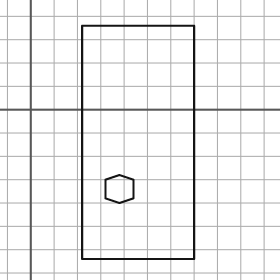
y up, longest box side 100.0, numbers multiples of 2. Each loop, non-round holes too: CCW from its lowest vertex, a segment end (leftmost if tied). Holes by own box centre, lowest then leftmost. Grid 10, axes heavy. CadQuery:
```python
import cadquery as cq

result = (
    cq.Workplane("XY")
    .moveTo(22.0, -64.0)
    .lineTo(70.0, -64.0)
    .lineTo(70.0, 36.0)
    .lineTo(22.0, 36.0)
    .close()
    .moveTo(38.0, -40.0)
    .lineTo(44.0, -38.0)
    .lineTo(44.0, -30.0)
    .lineTo(38.0, -28.0)
    .lineTo(32.0, -30.0)
    .lineTo(32.0, -38.0)
    .close()
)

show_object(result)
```